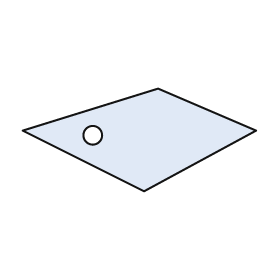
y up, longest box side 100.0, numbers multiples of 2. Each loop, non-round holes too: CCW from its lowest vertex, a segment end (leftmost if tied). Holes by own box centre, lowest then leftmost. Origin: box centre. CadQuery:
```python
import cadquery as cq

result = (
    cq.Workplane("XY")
    .moveTo(2.0, -22.0)
    .lineTo(50.0, 4.0)
    .lineTo(8.0, 22.0)
    .lineTo(-50.0, 4.0)
    .close()
    .moveTo(-20.0, 2.0)
    .circle(4.0)
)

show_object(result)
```